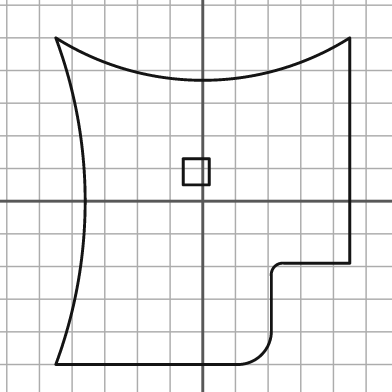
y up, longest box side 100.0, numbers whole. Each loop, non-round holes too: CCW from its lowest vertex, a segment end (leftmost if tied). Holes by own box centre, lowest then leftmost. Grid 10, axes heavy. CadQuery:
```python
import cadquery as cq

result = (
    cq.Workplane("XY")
    .moveTo(-45.0, -50.0)
    .lineTo(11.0, -50.0)
    .threePointArc((18.0, -47.0), (21.0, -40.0))
    .lineTo(21.0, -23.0)
    .threePointArc((22.0, -20.0), (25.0, -19.0))
    .lineTo(45.0, -19.0)
    .lineTo(45.0, 50.0)
    .threePointArc((0.0, 37.0), (-45.0, 50.0))
    .threePointArc((-36.0, 0.0), (-45.0, -50.0))
    .close()
    .moveTo(-6.0, 5.0)
    .lineTo(2.0, 5.0)
    .lineTo(2.0, 13.0)
    .lineTo(-6.0, 13.0)
    .close()
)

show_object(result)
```